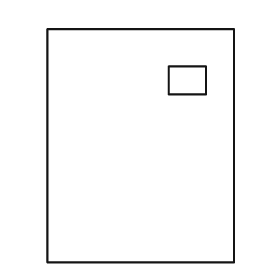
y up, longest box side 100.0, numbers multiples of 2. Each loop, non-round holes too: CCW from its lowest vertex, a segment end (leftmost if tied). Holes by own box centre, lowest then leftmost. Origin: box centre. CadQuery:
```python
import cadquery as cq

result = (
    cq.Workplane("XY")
    .moveTo(-40.0, -50.0)
    .lineTo(40.0, -50.0)
    .lineTo(40.0, 50.0)
    .lineTo(-40.0, 50.0)
    .close()
    .moveTo(12.0, 22.0)
    .lineTo(28.0, 22.0)
    .lineTo(28.0, 34.0)
    .lineTo(12.0, 34.0)
    .close()
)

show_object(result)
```